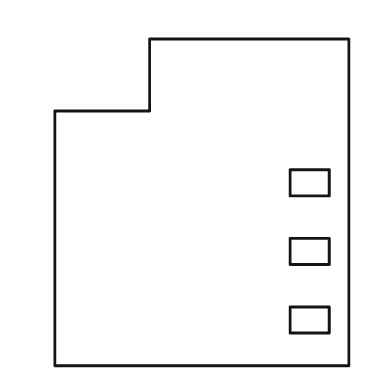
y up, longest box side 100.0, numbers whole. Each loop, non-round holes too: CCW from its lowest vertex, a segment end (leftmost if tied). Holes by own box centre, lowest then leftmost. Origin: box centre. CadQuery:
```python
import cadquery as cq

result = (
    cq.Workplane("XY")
    .moveTo(-45.0, -50.0)
    .lineTo(45.0, -50.0)
    .lineTo(45.0, 50.0)
    .lineTo(-16.0, 50.0)
    .lineTo(-16.0, 28.0)
    .lineTo(-45.0, 28.0)
    .close()
    .moveTo(27.0, -40.0)
    .lineTo(39.0, -40.0)
    .lineTo(39.0, -32.0)
    .lineTo(27.0, -32.0)
    .close()
    .moveTo(27.0, -19.0)
    .lineTo(39.0, -19.0)
    .lineTo(39.0, -11.0)
    .lineTo(27.0, -11.0)
    .close()
    .moveTo(27.0, 2.0)
    .lineTo(39.0, 2.0)
    .lineTo(39.0, 10.0)
    .lineTo(27.0, 10.0)
    .close()
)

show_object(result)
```